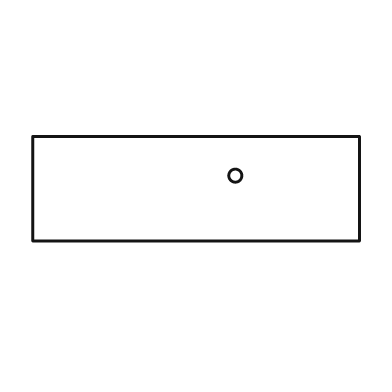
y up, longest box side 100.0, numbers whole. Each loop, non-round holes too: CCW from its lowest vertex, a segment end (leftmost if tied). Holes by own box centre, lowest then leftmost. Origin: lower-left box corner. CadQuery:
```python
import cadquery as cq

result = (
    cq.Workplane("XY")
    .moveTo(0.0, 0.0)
    .lineTo(100.0, 0.0)
    .lineTo(100.0, 32.0)
    .lineTo(0.0, 32.0)
    .close()
    .moveTo(62.0, 20.0)
    .circle(2.0)
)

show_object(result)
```